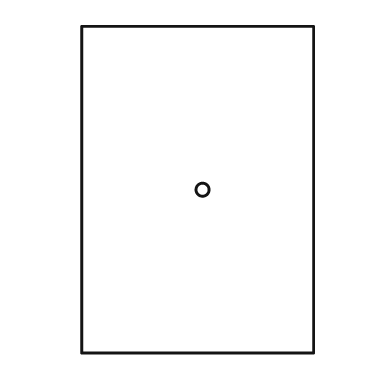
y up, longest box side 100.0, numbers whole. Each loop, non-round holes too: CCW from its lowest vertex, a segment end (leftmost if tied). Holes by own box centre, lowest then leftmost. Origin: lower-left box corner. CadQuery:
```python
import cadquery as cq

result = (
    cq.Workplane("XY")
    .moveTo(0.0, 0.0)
    .lineTo(71.0, 0.0)
    .lineTo(71.0, 100.0)
    .lineTo(0.0, 100.0)
    .close()
    .moveTo(37.0, 50.0)
    .circle(2.0)
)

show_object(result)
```